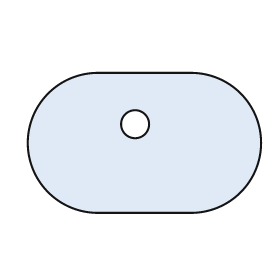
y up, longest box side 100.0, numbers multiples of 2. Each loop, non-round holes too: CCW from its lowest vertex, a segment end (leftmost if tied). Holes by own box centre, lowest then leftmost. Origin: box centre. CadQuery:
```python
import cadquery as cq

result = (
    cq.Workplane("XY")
    .moveTo(-20.0, -30.0)
    .lineTo(20.0, -30.0)
    .threePointArc((50.0, 0.0), (20.0, 30.0))
    .lineTo(-20.0, 30.0)
    .threePointArc((-50.0, 0.0), (-20.0, -30.0))
    .close()
    .moveTo(-4.0, 8.0)
    .circle(6.0)
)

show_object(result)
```